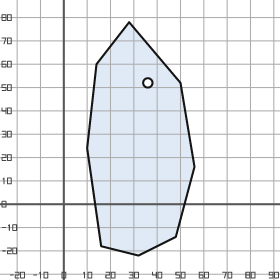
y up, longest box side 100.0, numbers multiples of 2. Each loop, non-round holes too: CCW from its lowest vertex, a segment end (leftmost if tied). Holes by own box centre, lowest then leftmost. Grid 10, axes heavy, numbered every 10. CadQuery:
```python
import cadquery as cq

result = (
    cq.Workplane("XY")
    .moveTo(32.0, -22.0)
    .lineTo(48.0, -14.0)
    .lineTo(56.0, 16.0)
    .lineTo(50.0, 52.0)
    .lineTo(28.0, 78.0)
    .lineTo(14.0, 60.0)
    .lineTo(10.0, 24.0)
    .lineTo(16.0, -18.0)
    .close()
    .moveTo(36.0, 52.0)
    .circle(2.0)
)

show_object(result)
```